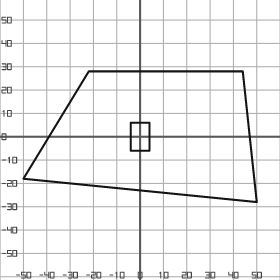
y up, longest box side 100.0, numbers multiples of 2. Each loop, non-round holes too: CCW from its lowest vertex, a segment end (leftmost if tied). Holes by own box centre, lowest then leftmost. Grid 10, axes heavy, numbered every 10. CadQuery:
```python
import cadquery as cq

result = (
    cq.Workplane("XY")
    .moveTo(50.0, -28.0)
    .lineTo(44.0, 28.0)
    .lineTo(-22.0, 28.0)
    .lineTo(-50.0, -18.0)
    .close()
    .moveTo(-4.0, -6.0)
    .lineTo(4.0, -6.0)
    .lineTo(4.0, 6.0)
    .lineTo(-4.0, 6.0)
    .close()
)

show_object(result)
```